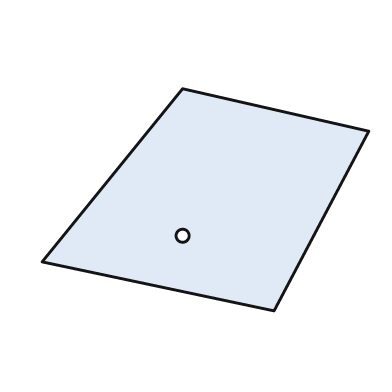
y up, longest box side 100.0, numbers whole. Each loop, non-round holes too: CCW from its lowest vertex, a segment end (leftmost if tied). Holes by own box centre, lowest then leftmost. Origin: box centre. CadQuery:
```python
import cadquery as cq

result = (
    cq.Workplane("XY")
    .moveTo(21.0, -34.0)
    .lineTo(50.0, 21.0)
    .lineTo(-7.0, 34.0)
    .lineTo(-50.0, -19.0)
    .close()
    .moveTo(-7.0, -11.0)
    .circle(2.0)
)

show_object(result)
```